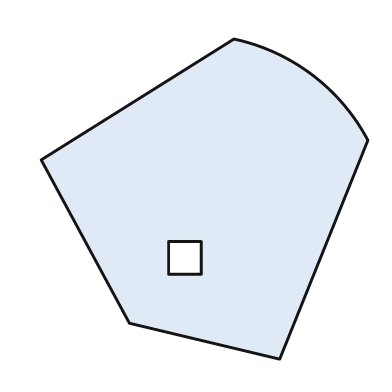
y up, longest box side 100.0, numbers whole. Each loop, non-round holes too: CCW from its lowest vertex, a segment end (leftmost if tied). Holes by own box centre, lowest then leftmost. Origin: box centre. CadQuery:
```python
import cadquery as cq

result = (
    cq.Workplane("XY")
    .moveTo(23.0, -49.0)
    .lineTo(50.0, 18.0)
    .threePointArc((33.0, 38.0), (9.0, 49.0))
    .lineTo(-50.0, 12.0)
    .lineTo(-23.0, -38.0)
    .close()
    .moveTo(-11.0, -23.0)
    .lineTo(-1.0, -23.0)
    .lineTo(-1.0, -13.0)
    .lineTo(-11.0, -13.0)
    .close()
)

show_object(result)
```